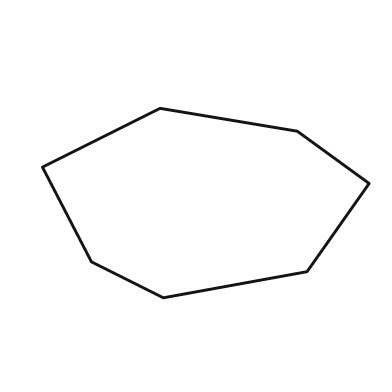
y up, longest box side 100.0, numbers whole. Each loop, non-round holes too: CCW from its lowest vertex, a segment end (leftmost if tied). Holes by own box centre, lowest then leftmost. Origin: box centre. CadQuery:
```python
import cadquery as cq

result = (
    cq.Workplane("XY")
    .moveTo(-13.0, -29.0)
    .lineTo(31.0, -21.0)
    .lineTo(50.0, 6.0)
    .lineTo(28.0, 22.0)
    .lineTo(-14.0, 29.0)
    .lineTo(-50.0, 11.0)
    .lineTo(-35.0, -18.0)
    .close()
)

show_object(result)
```